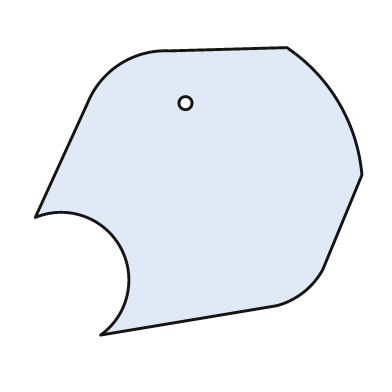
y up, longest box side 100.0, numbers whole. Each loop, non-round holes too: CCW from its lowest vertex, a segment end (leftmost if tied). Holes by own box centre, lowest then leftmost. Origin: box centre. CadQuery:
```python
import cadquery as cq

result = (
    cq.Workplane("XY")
    .moveTo(-30.0, -44.0)
    .lineTo(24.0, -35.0)
    .threePointArc((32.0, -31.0), (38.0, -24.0))
    .lineTo(50.0, 5.0)
    .threePointArc((43.0, 27.0), (27.0, 44.0))
    .lineTo(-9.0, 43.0)
    .threePointArc((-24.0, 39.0), (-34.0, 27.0))
    .lineTo(-50.0, -8.0)
    .threePointArc((-24.0, -17.0), (-30.0, -44.0))
    .close()
    .moveTo(-4.0, 27.0)
    .circle(2.0)
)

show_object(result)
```